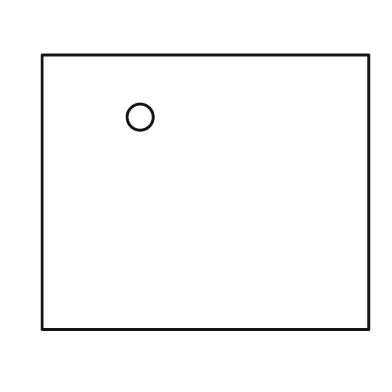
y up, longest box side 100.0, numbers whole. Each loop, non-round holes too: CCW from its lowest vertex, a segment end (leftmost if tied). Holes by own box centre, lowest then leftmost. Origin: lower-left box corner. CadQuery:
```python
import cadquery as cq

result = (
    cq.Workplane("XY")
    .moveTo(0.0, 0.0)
    .lineTo(100.0, 0.0)
    .lineTo(100.0, 84.0)
    .lineTo(0.0, 84.0)
    .close()
    .moveTo(30.0, 65.0)
    .circle(4.0)
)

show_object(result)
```